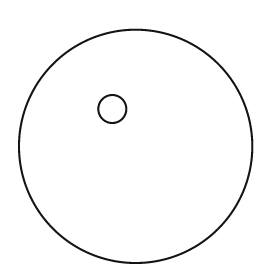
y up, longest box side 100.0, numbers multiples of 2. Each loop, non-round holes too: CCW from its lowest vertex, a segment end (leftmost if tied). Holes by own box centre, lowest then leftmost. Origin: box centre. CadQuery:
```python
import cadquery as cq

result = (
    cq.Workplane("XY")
    .moveTo(0.0, 0.0)
    .circle(50.0)
    .moveTo(-10.0, 16.0)
    .circle(6.0)
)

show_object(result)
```